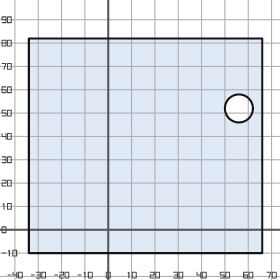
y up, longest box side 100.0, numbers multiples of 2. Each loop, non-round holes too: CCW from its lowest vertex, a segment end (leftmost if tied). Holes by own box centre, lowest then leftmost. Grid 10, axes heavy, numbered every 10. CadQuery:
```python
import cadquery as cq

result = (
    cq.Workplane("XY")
    .moveTo(-34.0, -10.0)
    .lineTo(66.0, -10.0)
    .lineTo(66.0, 82.0)
    .lineTo(-34.0, 82.0)
    .close()
    .moveTo(56.0, 52.0)
    .circle(6.0)
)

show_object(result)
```